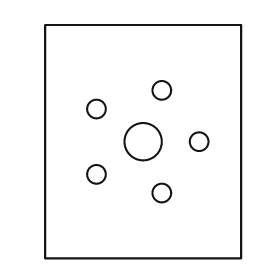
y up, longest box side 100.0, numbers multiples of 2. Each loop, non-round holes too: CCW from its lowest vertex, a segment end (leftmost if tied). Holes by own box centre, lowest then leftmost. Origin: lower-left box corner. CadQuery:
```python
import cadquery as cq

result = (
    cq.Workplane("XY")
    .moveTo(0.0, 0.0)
    .lineTo(84.0, 0.0)
    .lineTo(84.0, 100.0)
    .lineTo(0.0, 100.0)
    .close()
    .moveTo(50.0, 28.0)
    .circle(4.0)
    .moveTo(22.0, 36.0)
    .circle(4.0)
    .moveTo(42.0, 50.0)
    .circle(8.0)
    .moveTo(66.0, 50.0)
    .circle(4.0)
    .moveTo(22.0, 64.0)
    .circle(4.0)
    .moveTo(50.0, 72.0)
    .circle(4.0)
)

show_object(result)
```